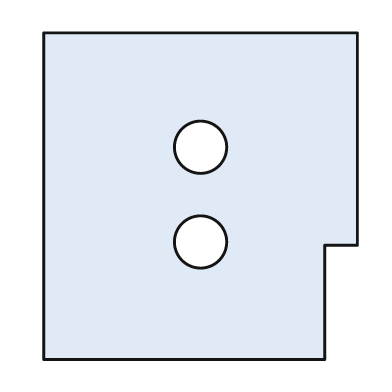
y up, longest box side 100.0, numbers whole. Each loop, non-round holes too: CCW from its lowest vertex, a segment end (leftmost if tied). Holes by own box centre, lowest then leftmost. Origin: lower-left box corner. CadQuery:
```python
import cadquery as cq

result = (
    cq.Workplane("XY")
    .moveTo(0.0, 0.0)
    .lineTo(86.0, 0.0)
    .lineTo(86.0, 35.0)
    .lineTo(96.0, 35.0)
    .lineTo(96.0, 100.0)
    .lineTo(0.0, 100.0)
    .close()
    .moveTo(48.0, 36.0)
    .circle(8.0)
    .moveTo(48.0, 65.0)
    .circle(8.0)
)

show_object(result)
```